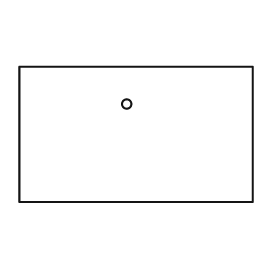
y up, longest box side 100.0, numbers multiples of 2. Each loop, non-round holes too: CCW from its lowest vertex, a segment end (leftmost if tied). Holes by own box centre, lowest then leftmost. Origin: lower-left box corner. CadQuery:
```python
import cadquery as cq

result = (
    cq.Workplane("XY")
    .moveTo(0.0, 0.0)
    .lineTo(100.0, 0.0)
    .lineTo(100.0, 58.0)
    .lineTo(0.0, 58.0)
    .close()
    .moveTo(46.0, 42.0)
    .circle(2.0)
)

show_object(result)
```